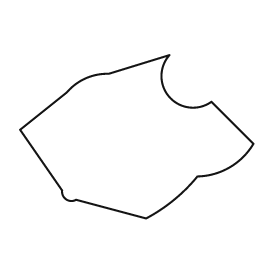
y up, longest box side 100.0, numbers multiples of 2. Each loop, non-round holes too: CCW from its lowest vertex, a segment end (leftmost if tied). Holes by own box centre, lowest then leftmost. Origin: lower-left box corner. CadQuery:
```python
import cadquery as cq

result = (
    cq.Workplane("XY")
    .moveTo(54.0, 0.0)
    .threePointArc((66.0, 8.0), (76.0, 18.0))
    .threePointArc((90.0, 22.0), (100.0, 32.0))
    .lineTo(82.0, 50.0)
    .threePointArc((64.0, 52.0), (64.0, 70.0))
    .lineTo(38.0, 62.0)
    .threePointArc((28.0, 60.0), (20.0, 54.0))
    .lineTo(0.0, 38.0)
    .lineTo(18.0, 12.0)
    .threePointArc((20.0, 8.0), (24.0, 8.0))
    .close()
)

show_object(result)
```